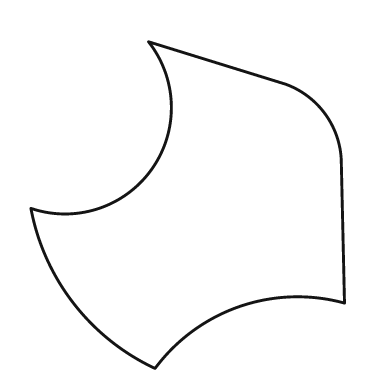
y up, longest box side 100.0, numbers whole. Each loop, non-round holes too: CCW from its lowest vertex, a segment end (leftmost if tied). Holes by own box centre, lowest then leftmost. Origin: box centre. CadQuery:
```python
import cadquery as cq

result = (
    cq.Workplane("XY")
    .moveTo(-10.0, -50.0)
    .threePointArc((16.0, -31.0), (48.0, -30.0))
    .lineTo(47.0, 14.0)
    .threePointArc((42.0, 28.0), (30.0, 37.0))
    .lineTo(-12.0, 50.0)
    .threePointArc((-11.0, 11.0), (-48.0, -1.0))
    .threePointArc((-35.0, -30.0), (-10.0, -50.0))
    .close()
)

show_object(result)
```